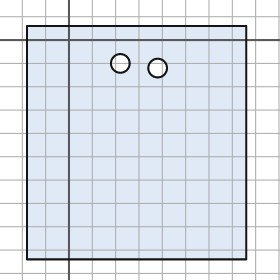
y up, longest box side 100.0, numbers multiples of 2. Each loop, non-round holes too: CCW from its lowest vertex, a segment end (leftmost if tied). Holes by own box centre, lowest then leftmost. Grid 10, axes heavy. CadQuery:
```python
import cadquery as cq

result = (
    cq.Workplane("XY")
    .moveTo(-18.0, -94.0)
    .lineTo(76.0, -94.0)
    .lineTo(76.0, 6.0)
    .lineTo(-18.0, 6.0)
    .close()
    .moveTo(38.0, -12.0)
    .circle(4.0)
    .moveTo(22.0, -10.0)
    .circle(4.0)
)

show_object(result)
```